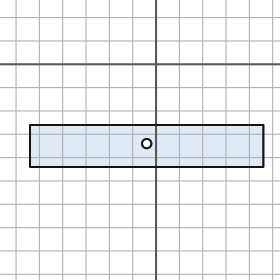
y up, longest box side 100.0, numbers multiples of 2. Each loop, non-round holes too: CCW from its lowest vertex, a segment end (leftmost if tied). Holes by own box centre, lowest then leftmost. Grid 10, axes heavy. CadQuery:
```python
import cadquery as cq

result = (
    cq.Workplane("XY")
    .moveTo(-54.0, -44.0)
    .lineTo(46.0, -44.0)
    .lineTo(46.0, -26.0)
    .lineTo(-54.0, -26.0)
    .close()
    .moveTo(-4.0, -34.0)
    .circle(2.0)
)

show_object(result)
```